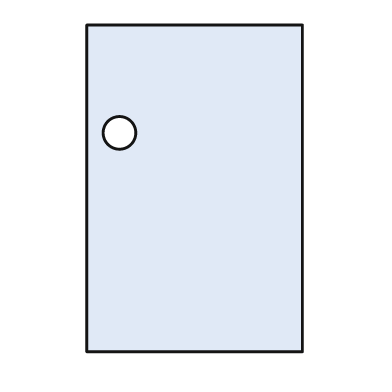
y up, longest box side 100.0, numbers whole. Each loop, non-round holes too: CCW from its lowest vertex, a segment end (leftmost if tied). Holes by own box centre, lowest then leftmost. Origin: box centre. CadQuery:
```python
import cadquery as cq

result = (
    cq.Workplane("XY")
    .moveTo(-33.0, -50.0)
    .lineTo(33.0, -50.0)
    .lineTo(33.0, 50.0)
    .lineTo(-33.0, 50.0)
    .close()
    .moveTo(-23.0, 17.0)
    .circle(5.0)
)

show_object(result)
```